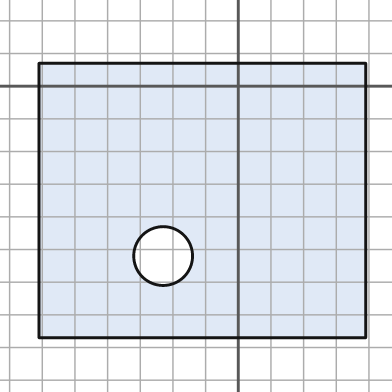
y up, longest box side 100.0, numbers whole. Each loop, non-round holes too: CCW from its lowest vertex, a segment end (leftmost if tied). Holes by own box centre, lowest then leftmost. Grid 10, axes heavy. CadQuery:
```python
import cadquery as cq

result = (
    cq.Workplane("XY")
    .moveTo(-61.0, -77.0)
    .lineTo(39.0, -77.0)
    .lineTo(39.0, 7.0)
    .lineTo(-61.0, 7.0)
    .close()
    .moveTo(-23.0, -52.0)
    .circle(9.0)
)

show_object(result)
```